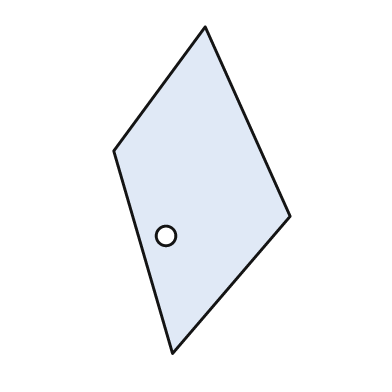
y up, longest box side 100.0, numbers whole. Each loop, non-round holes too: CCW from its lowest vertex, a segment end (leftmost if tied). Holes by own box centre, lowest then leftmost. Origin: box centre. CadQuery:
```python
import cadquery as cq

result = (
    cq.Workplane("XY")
    .moveTo(-9.0, -50.0)
    .lineTo(27.0, -8.0)
    .lineTo(1.0, 50.0)
    .lineTo(-27.0, 12.0)
    .close()
    .moveTo(-11.0, -14.0)
    .circle(3.0)
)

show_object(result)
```